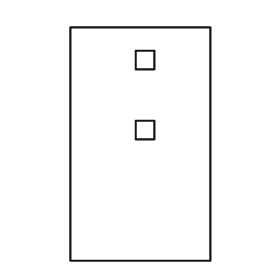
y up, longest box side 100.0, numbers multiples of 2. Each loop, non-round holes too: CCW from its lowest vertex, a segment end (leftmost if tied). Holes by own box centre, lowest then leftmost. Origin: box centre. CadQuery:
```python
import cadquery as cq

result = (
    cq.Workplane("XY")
    .moveTo(-30.0, -50.0)
    .lineTo(30.0, -50.0)
    .lineTo(30.0, 50.0)
    .lineTo(-30.0, 50.0)
    .close()
    .moveTo(-2.0, 2.0)
    .lineTo(6.0, 2.0)
    .lineTo(6.0, 10.0)
    .lineTo(-2.0, 10.0)
    .close()
    .moveTo(-2.0, 32.0)
    .lineTo(6.0, 32.0)
    .lineTo(6.0, 40.0)
    .lineTo(-2.0, 40.0)
    .close()
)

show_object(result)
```